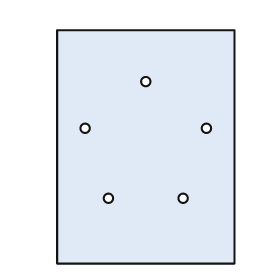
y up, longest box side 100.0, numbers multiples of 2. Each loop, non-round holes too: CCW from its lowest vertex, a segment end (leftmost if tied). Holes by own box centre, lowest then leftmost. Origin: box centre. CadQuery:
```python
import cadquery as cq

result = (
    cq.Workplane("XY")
    .moveTo(-38.0, -50.0)
    .lineTo(38.0, -50.0)
    .lineTo(38.0, 50.0)
    .lineTo(-38.0, 50.0)
    .close()
    .moveTo(-16.0, -22.0)
    .circle(2.0)
    .moveTo(16.0, -22.0)
    .circle(2.0)
    .moveTo(-26.0, 8.0)
    .circle(2.0)
    .moveTo(26.0, 8.0)
    .circle(2.0)
    .moveTo(0.0, 28.0)
    .circle(2.0)
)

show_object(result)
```